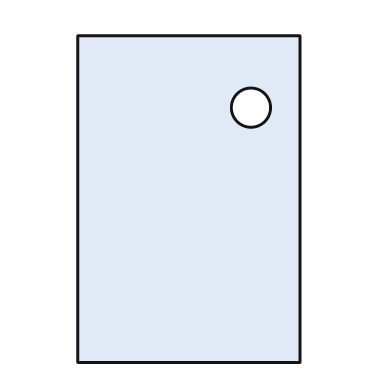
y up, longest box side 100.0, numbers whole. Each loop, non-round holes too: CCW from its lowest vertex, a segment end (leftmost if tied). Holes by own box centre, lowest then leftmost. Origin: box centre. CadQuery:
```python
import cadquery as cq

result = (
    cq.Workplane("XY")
    .moveTo(-34.0, -50.0)
    .lineTo(34.0, -50.0)
    .lineTo(34.0, 50.0)
    .lineTo(-34.0, 50.0)
    .close()
    .moveTo(19.0, 28.0)
    .circle(6.0)
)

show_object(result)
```